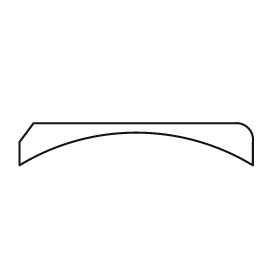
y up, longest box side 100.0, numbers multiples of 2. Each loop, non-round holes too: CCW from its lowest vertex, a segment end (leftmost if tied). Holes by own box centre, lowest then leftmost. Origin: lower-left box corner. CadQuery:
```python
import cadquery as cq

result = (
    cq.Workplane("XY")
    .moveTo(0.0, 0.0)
    .threePointArc((50.0, 14.0), (100.0, 0.0))
    .lineTo(100.0, 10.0)
    .threePointArc((98.0, 16.0), (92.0, 18.0))
    .lineTo(6.0, 18.0)
    .lineTo(0.0, 10.0)
    .close()
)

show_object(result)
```